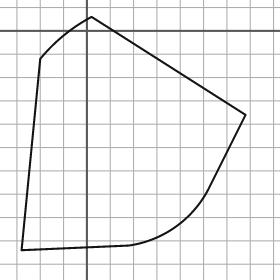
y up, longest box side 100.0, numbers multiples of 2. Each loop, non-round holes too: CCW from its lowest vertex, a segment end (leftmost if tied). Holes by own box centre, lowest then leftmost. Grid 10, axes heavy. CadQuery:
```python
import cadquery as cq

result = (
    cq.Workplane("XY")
    .moveTo(-28.0, -94.0)
    .lineTo(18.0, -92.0)
    .threePointArc((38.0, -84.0), (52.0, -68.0))
    .lineTo(68.0, -36.0)
    .lineTo(2.0, 6.0)
    .threePointArc((-10.0, -2.0), (-20.0, -12.0))
    .close()
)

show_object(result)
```